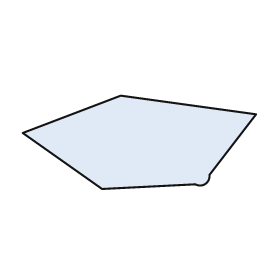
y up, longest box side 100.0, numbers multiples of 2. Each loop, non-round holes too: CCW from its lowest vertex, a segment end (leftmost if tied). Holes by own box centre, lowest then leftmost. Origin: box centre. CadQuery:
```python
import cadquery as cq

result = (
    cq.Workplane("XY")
    .moveTo(-16.0, -20.0)
    .lineTo(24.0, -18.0)
    .threePointArc((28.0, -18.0), (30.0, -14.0))
    .lineTo(50.0, 12.0)
    .lineTo(-8.0, 20.0)
    .lineTo(-50.0, 4.0)
    .close()
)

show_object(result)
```